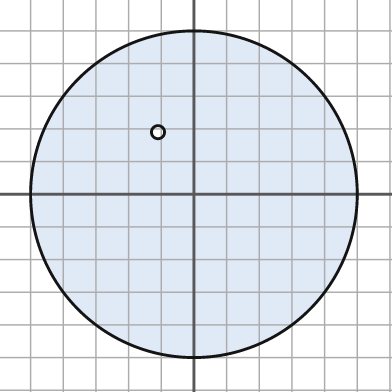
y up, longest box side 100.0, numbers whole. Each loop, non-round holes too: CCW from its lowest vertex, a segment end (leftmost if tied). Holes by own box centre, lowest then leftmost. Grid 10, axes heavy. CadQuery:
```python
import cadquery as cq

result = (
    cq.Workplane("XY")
    .moveTo(0.0, 0.0)
    .circle(50.0)
    .moveTo(-11.0, 19.0)
    .circle(2.0)
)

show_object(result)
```